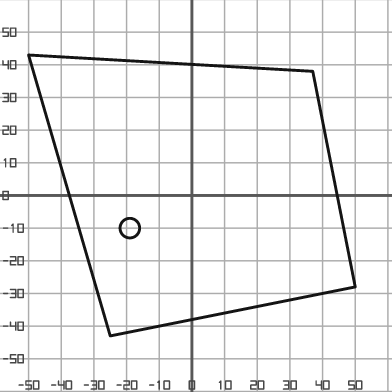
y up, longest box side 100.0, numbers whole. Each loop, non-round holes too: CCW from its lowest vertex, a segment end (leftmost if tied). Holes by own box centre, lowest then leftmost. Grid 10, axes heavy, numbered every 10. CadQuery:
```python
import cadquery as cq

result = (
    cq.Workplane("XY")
    .moveTo(-25.0, -43.0)
    .lineTo(50.0, -28.0)
    .lineTo(37.0, 38.0)
    .lineTo(-50.0, 43.0)
    .close()
    .moveTo(-19.0, -10.0)
    .circle(3.0)
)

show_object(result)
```